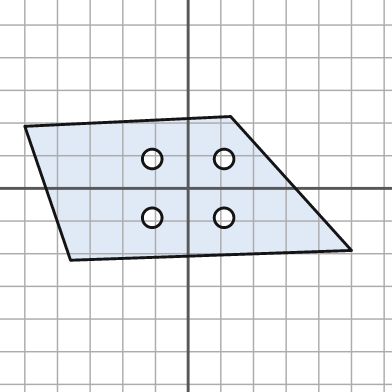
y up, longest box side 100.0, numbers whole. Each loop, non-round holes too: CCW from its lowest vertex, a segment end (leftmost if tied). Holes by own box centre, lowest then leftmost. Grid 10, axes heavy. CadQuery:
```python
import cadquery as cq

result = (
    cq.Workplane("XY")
    .moveTo(-36.0, -22.0)
    .lineTo(50.0, -19.0)
    .lineTo(13.0, 22.0)
    .lineTo(-50.0, 19.0)
    .close()
    .moveTo(-11.0, -9.0)
    .circle(3.0)
    .moveTo(11.0, -9.0)
    .circle(3.0)
    .moveTo(-11.0, 9.0)
    .circle(3.0)
    .moveTo(11.0, 9.0)
    .circle(3.0)
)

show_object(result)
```